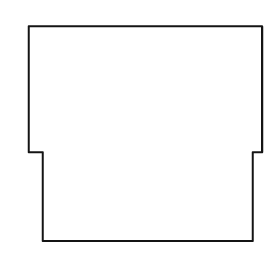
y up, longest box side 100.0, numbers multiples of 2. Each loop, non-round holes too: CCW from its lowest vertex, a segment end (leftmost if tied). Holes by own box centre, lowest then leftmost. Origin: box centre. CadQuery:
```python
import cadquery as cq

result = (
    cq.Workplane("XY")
    .moveTo(-44.0, -46.0)
    .lineTo(46.0, -46.0)
    .lineTo(46.0, -8.0)
    .lineTo(50.0, -8.0)
    .lineTo(50.0, 46.0)
    .lineTo(-50.0, 46.0)
    .lineTo(-50.0, -8.0)
    .lineTo(-44.0, -8.0)
    .close()
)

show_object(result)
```